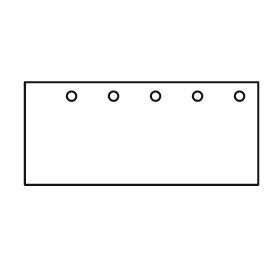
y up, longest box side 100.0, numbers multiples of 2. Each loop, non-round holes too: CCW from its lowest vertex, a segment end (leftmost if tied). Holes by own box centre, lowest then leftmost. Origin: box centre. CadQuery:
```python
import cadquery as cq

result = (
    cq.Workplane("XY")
    .moveTo(-50.0, -22.0)
    .lineTo(50.0, -22.0)
    .lineTo(50.0, 22.0)
    .lineTo(-50.0, 22.0)
    .close()
    .moveTo(-30.0, 16.0)
    .circle(2.0)
    .moveTo(-12.0, 16.0)
    .circle(2.0)
    .moveTo(6.0, 16.0)
    .circle(2.0)
    .moveTo(24.0, 16.0)
    .circle(2.0)
    .moveTo(42.0, 16.0)
    .circle(2.0)
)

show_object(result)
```